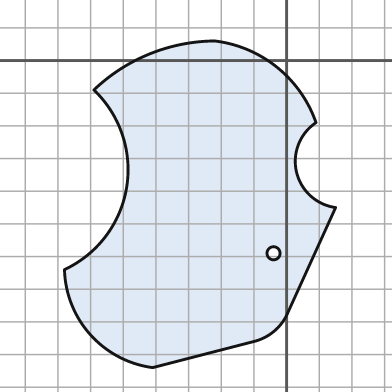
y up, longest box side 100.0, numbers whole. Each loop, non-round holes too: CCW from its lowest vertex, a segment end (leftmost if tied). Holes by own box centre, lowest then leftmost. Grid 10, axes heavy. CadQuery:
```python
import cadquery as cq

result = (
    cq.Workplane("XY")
    .moveTo(-41.0, -94.0)
    .lineTo(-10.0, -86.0)
    .threePointArc((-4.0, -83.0), (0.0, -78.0))
    .lineTo(15.0, -45.0)
    .threePointArc((3.0, -34.0), (9.0, -19.0))
    .threePointArc((-3.0, -2.0), (-22.0, 6.0))
    .threePointArc((-42.0, 2.0), (-59.0, -9.0))
    .threePointArc((-49.0, -39.0), (-68.0, -64.0))
    .threePointArc((-60.0, -84.0), (-41.0, -94.0))
    .close()
    .moveTo(-4.0, -59.0)
    .circle(2.0)
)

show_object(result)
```